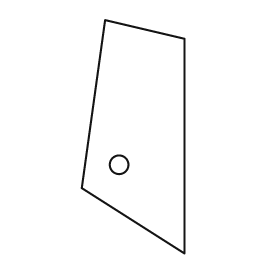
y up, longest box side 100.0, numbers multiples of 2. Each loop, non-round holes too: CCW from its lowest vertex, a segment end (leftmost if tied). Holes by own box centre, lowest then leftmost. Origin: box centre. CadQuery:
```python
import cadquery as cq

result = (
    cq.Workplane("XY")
    .moveTo(22.0, -50.0)
    .lineTo(22.0, 42.0)
    .lineTo(-12.0, 50.0)
    .lineTo(-22.0, -22.0)
    .close()
    .moveTo(-6.0, -12.0)
    .circle(4.0)
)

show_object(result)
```